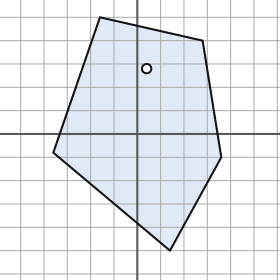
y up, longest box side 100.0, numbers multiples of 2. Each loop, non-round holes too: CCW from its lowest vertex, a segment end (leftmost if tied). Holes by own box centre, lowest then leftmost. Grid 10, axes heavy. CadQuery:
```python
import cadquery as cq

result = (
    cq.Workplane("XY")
    .moveTo(14.0, -50.0)
    .lineTo(36.0, -10.0)
    .lineTo(28.0, 40.0)
    .lineTo(-16.0, 50.0)
    .lineTo(-36.0, -8.0)
    .close()
    .moveTo(4.0, 28.0)
    .circle(2.0)
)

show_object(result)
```